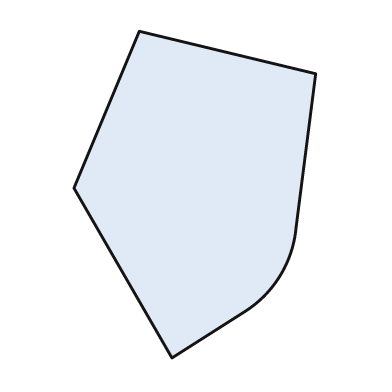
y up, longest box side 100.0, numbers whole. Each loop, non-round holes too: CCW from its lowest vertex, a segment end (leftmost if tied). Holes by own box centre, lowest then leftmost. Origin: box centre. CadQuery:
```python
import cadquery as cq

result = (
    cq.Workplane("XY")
    .moveTo(-7.0, -50.0)
    .lineTo(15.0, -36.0)
    .threePointArc((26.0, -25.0), (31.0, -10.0))
    .lineTo(37.0, 37.0)
    .lineTo(-17.0, 50.0)
    .lineTo(-37.0, 2.0)
    .close()
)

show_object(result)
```